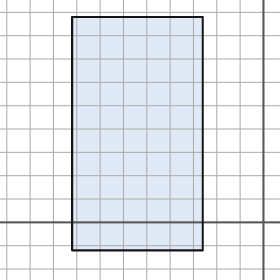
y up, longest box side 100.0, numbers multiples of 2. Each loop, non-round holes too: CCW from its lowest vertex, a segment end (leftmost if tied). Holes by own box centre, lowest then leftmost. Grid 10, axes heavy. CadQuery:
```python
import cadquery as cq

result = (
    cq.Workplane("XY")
    .moveTo(-82.0, -12.0)
    .lineTo(-26.0, -12.0)
    .lineTo(-26.0, 88.0)
    .lineTo(-82.0, 88.0)
    .close()
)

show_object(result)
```